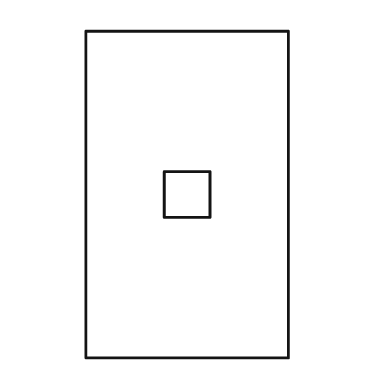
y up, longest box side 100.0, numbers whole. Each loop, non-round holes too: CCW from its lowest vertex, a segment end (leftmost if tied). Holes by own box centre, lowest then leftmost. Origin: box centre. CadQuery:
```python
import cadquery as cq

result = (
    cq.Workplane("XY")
    .moveTo(-31.0, -50.0)
    .lineTo(31.0, -50.0)
    .lineTo(31.0, 50.0)
    .lineTo(-31.0, 50.0)
    .close()
    .moveTo(-7.0, -7.0)
    .lineTo(7.0, -7.0)
    .lineTo(7.0, 7.0)
    .lineTo(-7.0, 7.0)
    .close()
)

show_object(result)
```